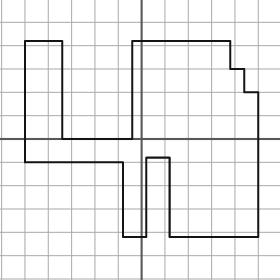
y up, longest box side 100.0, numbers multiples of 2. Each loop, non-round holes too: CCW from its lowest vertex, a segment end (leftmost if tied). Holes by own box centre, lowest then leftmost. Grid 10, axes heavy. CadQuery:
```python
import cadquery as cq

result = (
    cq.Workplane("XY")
    .moveTo(-8.0, -42.0)
    .lineTo(2.0, -42.0)
    .lineTo(2.0, -8.0)
    .lineTo(12.0, -8.0)
    .lineTo(12.0, -42.0)
    .lineTo(50.0, -42.0)
    .lineTo(50.0, 20.0)
    .lineTo(44.0, 20.0)
    .lineTo(44.0, 30.0)
    .lineTo(38.0, 30.0)
    .lineTo(38.0, 42.0)
    .lineTo(-4.0, 42.0)
    .lineTo(-4.0, 0.0)
    .lineTo(-34.0, 0.0)
    .lineTo(-34.0, 42.0)
    .lineTo(-50.0, 42.0)
    .lineTo(-50.0, -10.0)
    .lineTo(-8.0, -10.0)
    .close()
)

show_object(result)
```